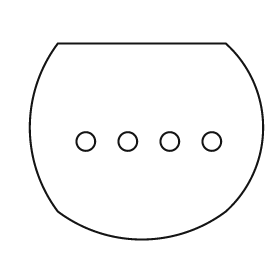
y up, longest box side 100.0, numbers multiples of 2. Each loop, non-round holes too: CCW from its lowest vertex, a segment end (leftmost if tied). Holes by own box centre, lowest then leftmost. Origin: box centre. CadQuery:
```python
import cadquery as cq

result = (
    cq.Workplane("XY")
    .moveTo(-38.0, -30.0)
    .threePointArc((-2.0, -42.0), (34.0, -30.0))
    .threePointArc((50.0, 6.0), (34.0, 42.0))
    .lineTo(-38.0, 42.0)
    .threePointArc((-50.0, 6.0), (-38.0, -30.0))
    .close()
    .moveTo(-26.0, 0.0)
    .circle(4.0)
    .moveTo(-8.0, 0.0)
    .circle(4.0)
    .moveTo(10.0, 0.0)
    .circle(4.0)
    .moveTo(28.0, 0.0)
    .circle(4.0)
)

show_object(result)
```